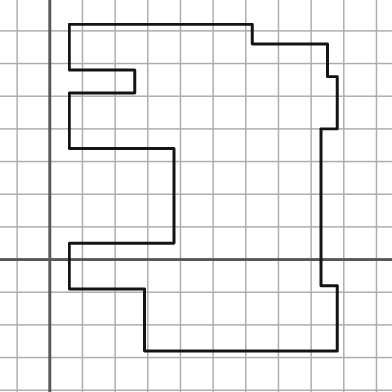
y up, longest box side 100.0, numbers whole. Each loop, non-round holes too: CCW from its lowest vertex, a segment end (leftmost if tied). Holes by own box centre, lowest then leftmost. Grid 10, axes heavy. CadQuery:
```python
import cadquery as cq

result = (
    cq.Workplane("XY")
    .moveTo(29.0, -28.0)
    .lineTo(88.0, -28.0)
    .lineTo(88.0, -8.0)
    .lineTo(83.0, -8.0)
    .lineTo(83.0, 40.0)
    .lineTo(88.0, 40.0)
    .lineTo(88.0, 56.0)
    .lineTo(85.0, 56.0)
    .lineTo(85.0, 66.0)
    .lineTo(62.0, 66.0)
    .lineTo(62.0, 72.0)
    .lineTo(6.0, 72.0)
    .lineTo(6.0, 58.0)
    .lineTo(26.0, 58.0)
    .lineTo(26.0, 51.0)
    .lineTo(6.0, 51.0)
    .lineTo(6.0, 34.0)
    .lineTo(38.0, 34.0)
    .lineTo(38.0, 5.0)
    .lineTo(6.0, 5.0)
    .lineTo(6.0, -9.0)
    .lineTo(29.0, -9.0)
    .close()
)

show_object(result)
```